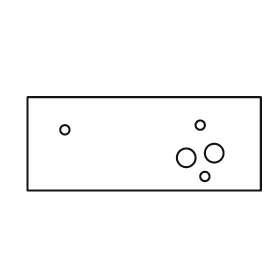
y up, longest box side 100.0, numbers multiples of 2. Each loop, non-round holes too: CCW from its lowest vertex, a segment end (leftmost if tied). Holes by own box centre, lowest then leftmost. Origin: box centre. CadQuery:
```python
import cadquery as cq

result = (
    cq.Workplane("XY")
    .moveTo(-50.0, -20.0)
    .lineTo(50.0, -20.0)
    .lineTo(50.0, 20.0)
    .lineTo(-50.0, 20.0)
    .close()
    .moveTo(26.0, -14.0)
    .circle(2.0)
    .moveTo(18.0, -6.0)
    .circle(4.0)
    .moveTo(30.0, -4.0)
    .circle(4.0)
    .moveTo(-34.0, 6.0)
    .circle(2.0)
    .moveTo(24.0, 8.0)
    .circle(2.0)
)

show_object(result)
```